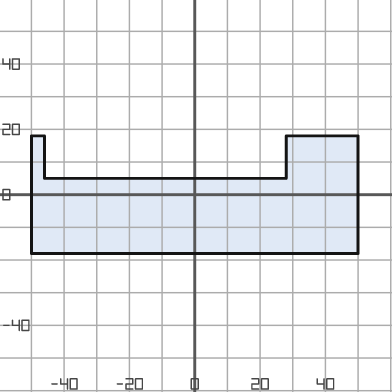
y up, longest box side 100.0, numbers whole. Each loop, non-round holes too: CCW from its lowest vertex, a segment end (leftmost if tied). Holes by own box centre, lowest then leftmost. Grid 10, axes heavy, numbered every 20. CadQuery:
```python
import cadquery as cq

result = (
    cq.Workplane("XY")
    .moveTo(-50.0, -18.0)
    .lineTo(50.0, -18.0)
    .lineTo(50.0, 18.0)
    .lineTo(28.0, 18.0)
    .lineTo(28.0, 5.0)
    .lineTo(-46.0, 5.0)
    .lineTo(-46.0, 18.0)
    .lineTo(-50.0, 18.0)
    .close()
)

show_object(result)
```